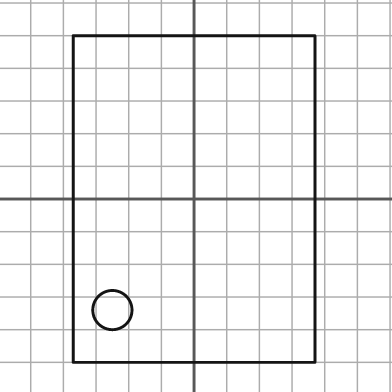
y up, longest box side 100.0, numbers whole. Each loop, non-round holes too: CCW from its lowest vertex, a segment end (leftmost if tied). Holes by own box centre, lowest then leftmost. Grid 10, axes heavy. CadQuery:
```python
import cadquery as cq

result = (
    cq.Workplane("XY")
    .moveTo(-37.0, -50.0)
    .lineTo(37.0, -50.0)
    .lineTo(37.0, 50.0)
    .lineTo(-37.0, 50.0)
    .close()
    .moveTo(-25.0, -34.0)
    .circle(6.0)
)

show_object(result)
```